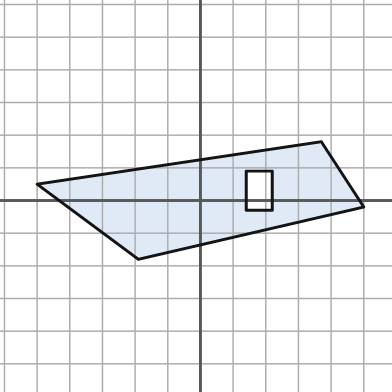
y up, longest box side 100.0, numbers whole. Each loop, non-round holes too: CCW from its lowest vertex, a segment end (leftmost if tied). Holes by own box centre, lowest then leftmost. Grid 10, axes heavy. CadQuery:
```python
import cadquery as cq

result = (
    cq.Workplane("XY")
    .moveTo(-19.0, -18.0)
    .lineTo(50.0, -2.0)
    .lineTo(37.0, 18.0)
    .lineTo(-50.0, 5.0)
    .close()
    .moveTo(14.0, -3.0)
    .lineTo(22.0, -3.0)
    .lineTo(22.0, 9.0)
    .lineTo(14.0, 9.0)
    .close()
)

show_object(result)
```